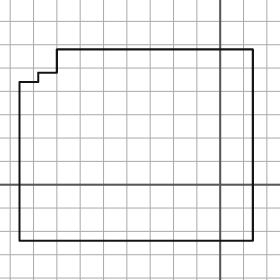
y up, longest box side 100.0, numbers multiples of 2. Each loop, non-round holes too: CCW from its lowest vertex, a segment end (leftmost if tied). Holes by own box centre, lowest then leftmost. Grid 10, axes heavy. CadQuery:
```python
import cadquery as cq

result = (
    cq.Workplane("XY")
    .moveTo(-86.0, -24.0)
    .lineTo(14.0, -24.0)
    .lineTo(14.0, 58.0)
    .lineTo(-70.0, 58.0)
    .lineTo(-70.0, 48.0)
    .lineTo(-78.0, 48.0)
    .lineTo(-78.0, 44.0)
    .lineTo(-86.0, 44.0)
    .close()
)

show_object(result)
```